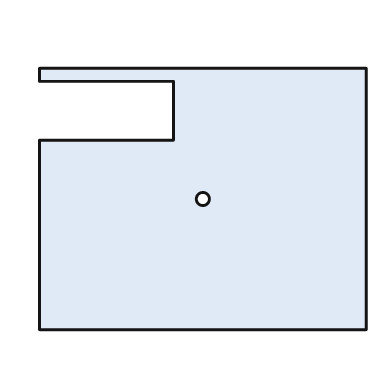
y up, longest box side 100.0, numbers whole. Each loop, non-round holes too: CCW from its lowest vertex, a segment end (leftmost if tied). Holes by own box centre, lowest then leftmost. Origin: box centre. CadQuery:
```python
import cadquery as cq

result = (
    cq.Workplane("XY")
    .moveTo(-50.0, -40.0)
    .lineTo(50.0, -40.0)
    .lineTo(50.0, 40.0)
    .lineTo(-50.0, 40.0)
    .lineTo(-50.0, 36.0)
    .lineTo(-9.0, 36.0)
    .lineTo(-9.0, 18.0)
    .lineTo(-50.0, 18.0)
    .close()
    .moveTo(0.0, 0.0)
    .circle(2.0)
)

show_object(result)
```